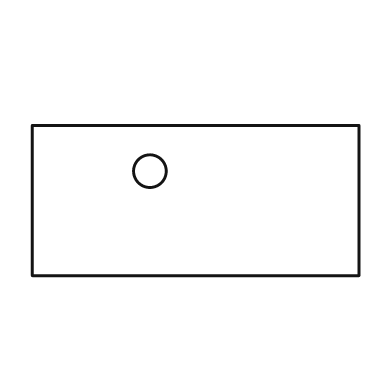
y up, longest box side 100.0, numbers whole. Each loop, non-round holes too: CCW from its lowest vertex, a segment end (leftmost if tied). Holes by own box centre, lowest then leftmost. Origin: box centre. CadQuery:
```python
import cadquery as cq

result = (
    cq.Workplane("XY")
    .moveTo(-50.0, -23.0)
    .lineTo(50.0, -23.0)
    .lineTo(50.0, 23.0)
    .lineTo(-50.0, 23.0)
    .close()
    .moveTo(-14.0, 9.0)
    .circle(5.0)
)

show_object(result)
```